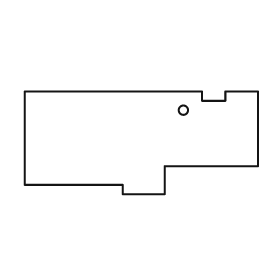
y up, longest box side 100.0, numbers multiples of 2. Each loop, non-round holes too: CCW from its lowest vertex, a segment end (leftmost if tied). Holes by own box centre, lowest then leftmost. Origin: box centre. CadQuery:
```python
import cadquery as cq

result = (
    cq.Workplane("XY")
    .moveTo(-8.0, -22.0)
    .lineTo(10.0, -22.0)
    .lineTo(10.0, -10.0)
    .lineTo(50.0, -10.0)
    .lineTo(50.0, 22.0)
    .lineTo(36.0, 22.0)
    .lineTo(36.0, 18.0)
    .lineTo(26.0, 18.0)
    .lineTo(26.0, 22.0)
    .lineTo(-50.0, 22.0)
    .lineTo(-50.0, -18.0)
    .lineTo(-8.0, -18.0)
    .close()
    .moveTo(18.0, 14.0)
    .circle(2.0)
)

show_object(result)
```